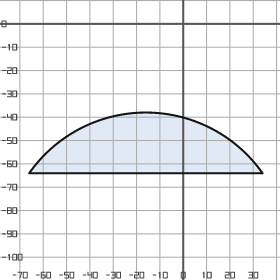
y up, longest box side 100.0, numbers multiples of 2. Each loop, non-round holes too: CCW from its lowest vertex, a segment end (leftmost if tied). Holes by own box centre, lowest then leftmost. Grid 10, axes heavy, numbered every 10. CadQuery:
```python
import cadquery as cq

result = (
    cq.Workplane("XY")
    .moveTo(-66.0, -64.0)
    .lineTo(34.0, -64.0)
    .threePointArc((-16.0, -38.0), (-66.0, -64.0))
    .close()
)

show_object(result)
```